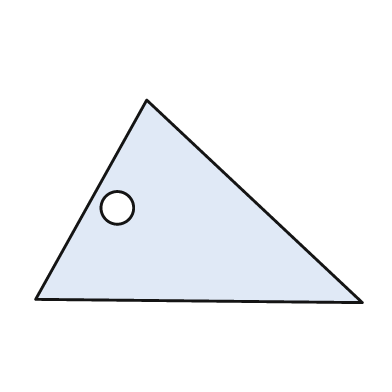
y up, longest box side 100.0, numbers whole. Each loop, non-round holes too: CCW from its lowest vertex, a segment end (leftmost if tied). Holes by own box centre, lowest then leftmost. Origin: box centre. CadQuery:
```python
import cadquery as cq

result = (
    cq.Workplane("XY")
    .moveTo(50.0, -31.0)
    .lineTo(-16.0, 31.0)
    .lineTo(-50.0, -30.0)
    .close()
    .moveTo(-25.0, -2.0)
    .circle(5.0)
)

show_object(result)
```